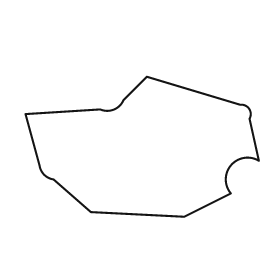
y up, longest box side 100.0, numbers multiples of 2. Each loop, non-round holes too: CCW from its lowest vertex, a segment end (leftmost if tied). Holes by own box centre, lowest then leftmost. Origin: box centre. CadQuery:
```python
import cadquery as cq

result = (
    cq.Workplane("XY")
    .moveTo(18.0, -30.0)
    .lineTo(38.0, -20.0)
    .threePointArc((38.0, -8.0), (50.0, -6.0))
    .lineTo(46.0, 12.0)
    .threePointArc((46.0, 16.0), (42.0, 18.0))
    .lineTo(2.0, 30.0)
    .lineTo(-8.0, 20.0)
    .threePointArc((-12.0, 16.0), (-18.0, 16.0))
    .lineTo(-50.0, 14.0)
    .lineTo(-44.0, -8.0)
    .threePointArc((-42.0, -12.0), (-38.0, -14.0))
    .lineTo(-22.0, -28.0)
    .close()
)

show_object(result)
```